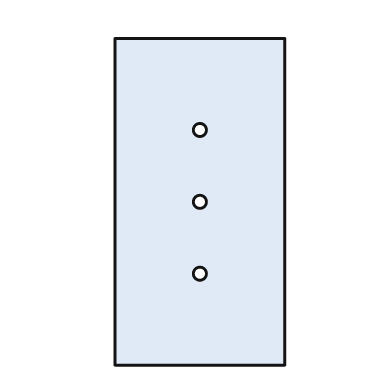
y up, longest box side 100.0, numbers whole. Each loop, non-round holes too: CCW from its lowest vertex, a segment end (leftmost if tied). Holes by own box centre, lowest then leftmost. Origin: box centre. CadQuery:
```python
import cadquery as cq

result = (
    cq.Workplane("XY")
    .moveTo(-26.0, -50.0)
    .lineTo(26.0, -50.0)
    .lineTo(26.0, 50.0)
    .lineTo(-26.0, 50.0)
    .close()
    .moveTo(0.0, -22.0)
    .circle(2.0)
    .moveTo(0.0, 0.0)
    .circle(2.0)
    .moveTo(0.0, 22.0)
    .circle(2.0)
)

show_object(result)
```